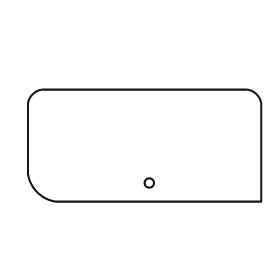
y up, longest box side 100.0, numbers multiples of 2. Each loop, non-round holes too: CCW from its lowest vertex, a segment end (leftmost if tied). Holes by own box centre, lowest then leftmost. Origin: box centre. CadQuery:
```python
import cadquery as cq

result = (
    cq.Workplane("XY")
    .moveTo(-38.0, -24.0)
    .lineTo(50.0, -24.0)
    .lineTo(50.0, 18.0)
    .threePointArc((48.0, 22.0), (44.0, 24.0))
    .lineTo(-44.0, 24.0)
    .threePointArc((-48.0, 22.0), (-50.0, 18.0))
    .lineTo(-50.0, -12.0)
    .threePointArc((-46.0, -20.0), (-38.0, -24.0))
    .close()
    .moveTo(2.0, -16.0)
    .circle(2.0)
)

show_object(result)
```